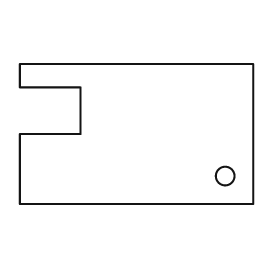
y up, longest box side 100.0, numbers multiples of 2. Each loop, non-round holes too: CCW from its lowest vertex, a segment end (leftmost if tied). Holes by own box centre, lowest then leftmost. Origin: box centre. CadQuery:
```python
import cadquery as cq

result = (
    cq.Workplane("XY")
    .moveTo(-50.0, -30.0)
    .lineTo(50.0, -30.0)
    .lineTo(50.0, 30.0)
    .lineTo(-50.0, 30.0)
    .lineTo(-50.0, 20.0)
    .lineTo(-24.0, 20.0)
    .lineTo(-24.0, 0.0)
    .lineTo(-50.0, 0.0)
    .close()
    .moveTo(38.0, -18.0)
    .circle(4.0)
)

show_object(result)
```